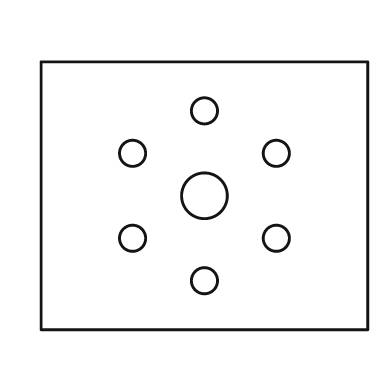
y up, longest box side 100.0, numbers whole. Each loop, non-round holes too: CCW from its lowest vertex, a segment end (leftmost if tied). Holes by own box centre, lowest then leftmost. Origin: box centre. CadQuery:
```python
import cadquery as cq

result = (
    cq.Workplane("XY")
    .moveTo(-50.0, -41.0)
    .lineTo(50.0, -41.0)
    .lineTo(50.0, 41.0)
    .lineTo(-50.0, 41.0)
    .close()
    .moveTo(0.0, -26.0)
    .circle(4.0)
    .moveTo(-22.0, -13.0)
    .circle(4.0)
    .moveTo(22.0, -13.0)
    .circle(4.0)
    .moveTo(0.0, 0.0)
    .circle(7.0)
    .moveTo(-22.0, 13.0)
    .circle(4.0)
    .moveTo(22.0, 13.0)
    .circle(4.0)
    .moveTo(0.0, 26.0)
    .circle(4.0)
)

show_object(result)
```